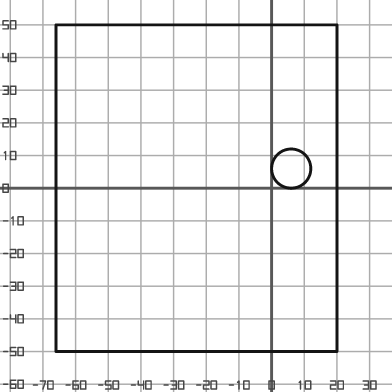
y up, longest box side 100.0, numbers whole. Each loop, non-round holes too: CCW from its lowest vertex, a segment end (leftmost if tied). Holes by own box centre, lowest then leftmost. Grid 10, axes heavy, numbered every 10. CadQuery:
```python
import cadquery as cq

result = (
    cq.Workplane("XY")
    .moveTo(-66.0, -50.0)
    .lineTo(20.0, -50.0)
    .lineTo(20.0, 50.0)
    .lineTo(-66.0, 50.0)
    .close()
    .moveTo(6.0, 6.0)
    .circle(6.0)
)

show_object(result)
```